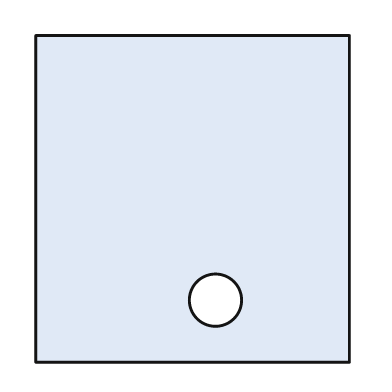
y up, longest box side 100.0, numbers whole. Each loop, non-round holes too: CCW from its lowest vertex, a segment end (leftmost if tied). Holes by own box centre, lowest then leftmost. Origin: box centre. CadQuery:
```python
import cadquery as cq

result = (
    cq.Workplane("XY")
    .moveTo(-48.0, -50.0)
    .lineTo(48.0, -50.0)
    .lineTo(48.0, 50.0)
    .lineTo(-48.0, 50.0)
    .close()
    .moveTo(7.0, -31.0)
    .circle(8.0)
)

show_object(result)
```